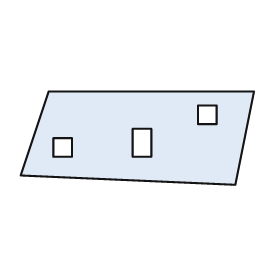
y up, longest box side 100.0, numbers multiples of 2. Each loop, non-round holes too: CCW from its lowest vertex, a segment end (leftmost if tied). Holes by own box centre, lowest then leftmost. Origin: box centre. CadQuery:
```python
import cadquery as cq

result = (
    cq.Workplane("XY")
    .moveTo(42.0, -20.0)
    .lineTo(50.0, 20.0)
    .lineTo(-38.0, 20.0)
    .lineTo(-50.0, -16.0)
    .close()
    .moveTo(-36.0, -8.0)
    .lineTo(-28.0, -8.0)
    .lineTo(-28.0, 0.0)
    .lineTo(-36.0, 0.0)
    .close()
    .moveTo(-2.0, -8.0)
    .lineTo(6.0, -8.0)
    .lineTo(6.0, 4.0)
    .lineTo(-2.0, 4.0)
    .close()
    .moveTo(26.0, 6.0)
    .lineTo(34.0, 6.0)
    .lineTo(34.0, 14.0)
    .lineTo(26.0, 14.0)
    .close()
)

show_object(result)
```